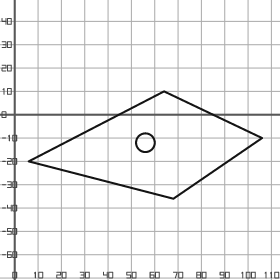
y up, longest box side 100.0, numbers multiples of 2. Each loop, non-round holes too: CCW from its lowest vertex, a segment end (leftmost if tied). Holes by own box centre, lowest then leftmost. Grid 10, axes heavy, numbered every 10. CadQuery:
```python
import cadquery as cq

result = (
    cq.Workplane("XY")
    .moveTo(68.0, -36.0)
    .lineTo(106.0, -10.0)
    .lineTo(64.0, 10.0)
    .lineTo(6.0, -20.0)
    .close()
    .moveTo(56.0, -12.0)
    .circle(4.0)
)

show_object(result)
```